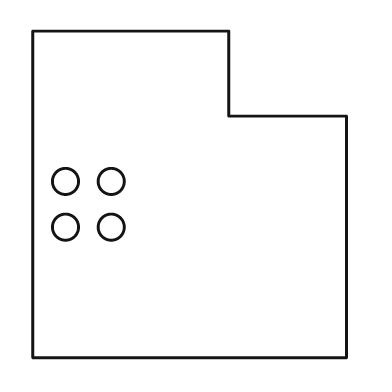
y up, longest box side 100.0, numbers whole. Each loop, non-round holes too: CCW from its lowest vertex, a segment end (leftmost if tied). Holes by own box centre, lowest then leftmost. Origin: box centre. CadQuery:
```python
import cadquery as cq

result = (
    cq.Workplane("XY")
    .moveTo(-48.0, -50.0)
    .lineTo(48.0, -50.0)
    .lineTo(48.0, 24.0)
    .lineTo(12.0, 24.0)
    .lineTo(12.0, 50.0)
    .lineTo(-48.0, 50.0)
    .close()
    .moveTo(-38.0, -10.0)
    .circle(4.0)
    .moveTo(-24.0, -10.0)
    .circle(4.0)
    .moveTo(-38.0, 4.0)
    .circle(4.0)
    .moveTo(-24.0, 4.0)
    .circle(4.0)
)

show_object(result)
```